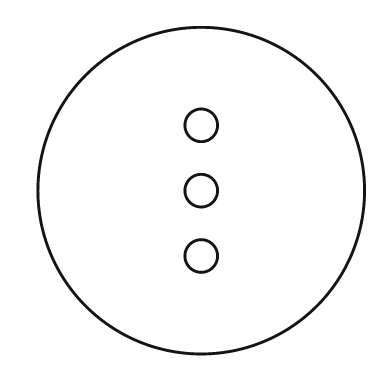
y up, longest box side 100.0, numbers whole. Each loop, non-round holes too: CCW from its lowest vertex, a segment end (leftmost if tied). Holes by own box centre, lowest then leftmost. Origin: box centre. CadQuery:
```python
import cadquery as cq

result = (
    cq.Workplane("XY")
    .moveTo(0.0, 0.0)
    .circle(50.0)
    .moveTo(0.0, -20.0)
    .circle(5.0)
    .moveTo(0.0, 0.0)
    .circle(5.0)
    .moveTo(0.0, 20.0)
    .circle(5.0)
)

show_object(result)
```